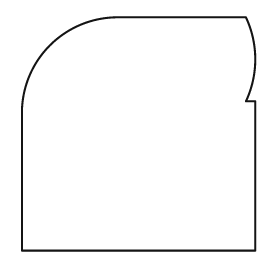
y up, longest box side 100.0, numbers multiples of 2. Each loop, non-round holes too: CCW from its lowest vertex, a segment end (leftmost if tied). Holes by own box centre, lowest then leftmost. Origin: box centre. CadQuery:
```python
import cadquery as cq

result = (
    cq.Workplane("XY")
    .moveTo(-50.0, -50.0)
    .lineTo(50.0, -50.0)
    .lineTo(50.0, 14.0)
    .lineTo(46.0, 14.0)
    .threePointArc((50.0, 32.0), (46.0, 50.0))
    .lineTo(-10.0, 50.0)
    .threePointArc((-38.0, 38.0), (-50.0, 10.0))
    .close()
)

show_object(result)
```